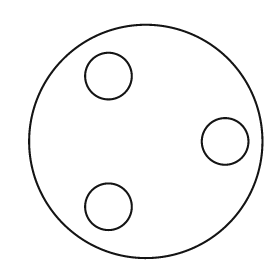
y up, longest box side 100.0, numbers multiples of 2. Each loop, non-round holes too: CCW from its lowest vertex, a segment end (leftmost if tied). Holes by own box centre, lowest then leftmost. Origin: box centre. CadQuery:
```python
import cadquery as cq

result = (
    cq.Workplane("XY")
    .moveTo(0.0, 0.0)
    .circle(50.0)
    .moveTo(-16.0, -28.0)
    .circle(10.0)
    .moveTo(34.0, 0.0)
    .circle(10.0)
    .moveTo(-16.0, 28.0)
    .circle(10.0)
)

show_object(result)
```